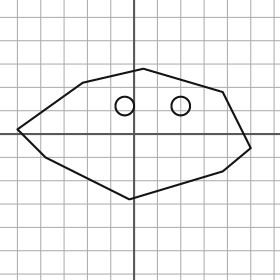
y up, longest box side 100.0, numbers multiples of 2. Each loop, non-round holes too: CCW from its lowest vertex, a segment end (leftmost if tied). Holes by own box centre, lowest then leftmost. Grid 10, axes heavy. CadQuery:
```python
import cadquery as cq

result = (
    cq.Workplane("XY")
    .moveTo(-2.0, -28.0)
    .lineTo(38.0, -16.0)
    .lineTo(50.0, -6.0)
    .lineTo(38.0, 18.0)
    .lineTo(4.0, 28.0)
    .lineTo(-22.0, 22.0)
    .lineTo(-50.0, 2.0)
    .lineTo(-38.0, -10.0)
    .close()
    .moveTo(-4.0, 12.0)
    .circle(4.0)
    .moveTo(20.0, 12.0)
    .circle(4.0)
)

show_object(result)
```